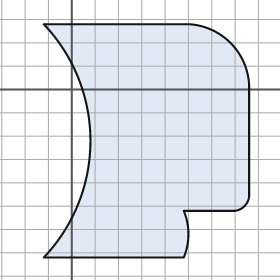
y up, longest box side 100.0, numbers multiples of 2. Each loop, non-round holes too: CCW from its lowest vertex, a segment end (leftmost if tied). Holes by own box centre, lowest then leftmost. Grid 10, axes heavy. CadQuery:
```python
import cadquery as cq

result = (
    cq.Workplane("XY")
    .moveTo(-12.0, -72.0)
    .lineTo(48.0, -72.0)
    .threePointArc((50.0, -62.0), (48.0, -52.0))
    .lineTo(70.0, -52.0)
    .threePointArc((74.0, -50.0), (76.0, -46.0))
    .lineTo(76.0, 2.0)
    .threePointArc((68.0, 20.0), (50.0, 28.0))
    .lineTo(-12.0, 28.0)
    .threePointArc((8.0, -22.0), (-12.0, -72.0))
    .close()
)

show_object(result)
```